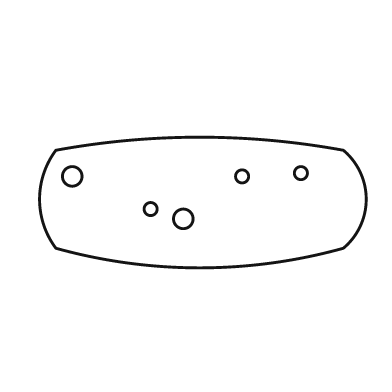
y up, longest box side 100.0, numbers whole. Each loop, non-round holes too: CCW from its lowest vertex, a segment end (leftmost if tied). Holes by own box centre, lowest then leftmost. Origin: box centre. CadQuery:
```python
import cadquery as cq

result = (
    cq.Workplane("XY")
    .moveTo(-45.0, -14.0)
    .threePointArc((-1.0, -20.0), (43.0, -14.0))
    .threePointArc((50.0, 1.0), (43.0, 16.0))
    .threePointArc((-1.0, 20.0), (-45.0, 16.0))
    .threePointArc((-50.0, 1.0), (-45.0, -14.0))
    .close()
    .moveTo(-6.0, -5.0)
    .circle(3.0)
    .moveTo(-16.0, -2.0)
    .circle(2.0)
    .moveTo(-40.0, 8.0)
    .circle(3.0)
    .moveTo(12.0, 8.0)
    .circle(2.0)
    .moveTo(30.0, 9.0)
    .circle(2.0)
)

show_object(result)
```